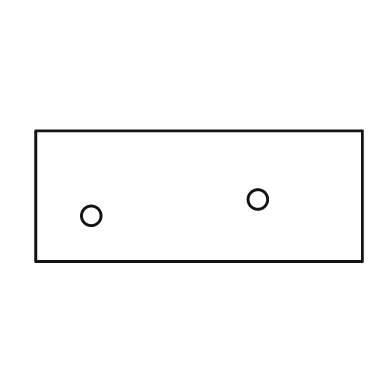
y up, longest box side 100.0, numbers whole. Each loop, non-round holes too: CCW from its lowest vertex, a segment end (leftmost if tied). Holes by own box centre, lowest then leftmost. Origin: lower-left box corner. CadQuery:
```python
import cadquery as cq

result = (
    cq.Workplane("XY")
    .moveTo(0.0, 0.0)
    .lineTo(100.0, 0.0)
    .lineTo(100.0, 40.0)
    .lineTo(0.0, 40.0)
    .close()
    .moveTo(17.0, 14.0)
    .circle(3.0)
    .moveTo(68.0, 19.0)
    .circle(3.0)
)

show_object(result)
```